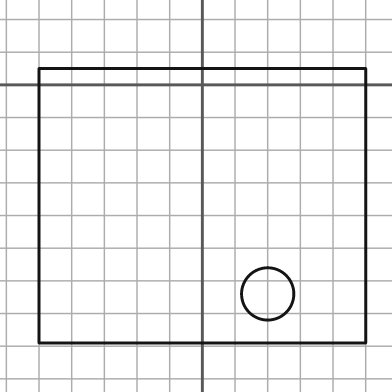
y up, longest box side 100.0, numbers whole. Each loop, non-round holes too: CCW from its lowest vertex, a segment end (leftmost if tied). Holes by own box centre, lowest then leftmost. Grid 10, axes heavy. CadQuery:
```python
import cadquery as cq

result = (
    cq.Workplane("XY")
    .moveTo(-50.0, -79.0)
    .lineTo(50.0, -79.0)
    .lineTo(50.0, 5.0)
    .lineTo(-50.0, 5.0)
    .close()
    .moveTo(20.0, -64.0)
    .circle(8.0)
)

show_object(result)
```